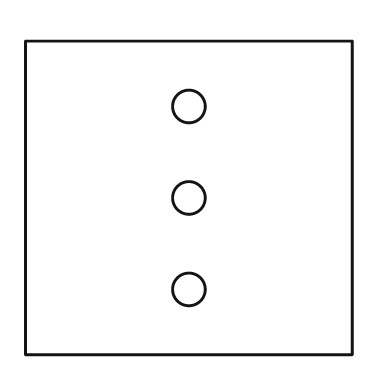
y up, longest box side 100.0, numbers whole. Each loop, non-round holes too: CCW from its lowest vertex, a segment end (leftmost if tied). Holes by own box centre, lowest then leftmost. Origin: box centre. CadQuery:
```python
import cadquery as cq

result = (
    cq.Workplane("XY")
    .moveTo(-50.0, -48.0)
    .lineTo(50.0, -48.0)
    .lineTo(50.0, 48.0)
    .lineTo(-50.0, 48.0)
    .close()
    .moveTo(0.0, -28.0)
    .circle(5.0)
    .moveTo(0.0, 0.0)
    .circle(5.0)
    .moveTo(0.0, 28.0)
    .circle(5.0)
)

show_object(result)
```